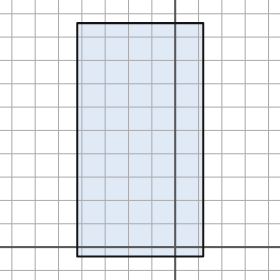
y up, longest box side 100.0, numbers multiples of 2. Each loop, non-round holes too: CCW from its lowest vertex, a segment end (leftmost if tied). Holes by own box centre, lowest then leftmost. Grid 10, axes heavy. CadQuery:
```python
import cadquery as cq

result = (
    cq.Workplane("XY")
    .moveTo(-42.0, -4.0)
    .lineTo(12.0, -4.0)
    .lineTo(12.0, 96.0)
    .lineTo(-42.0, 96.0)
    .close()
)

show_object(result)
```